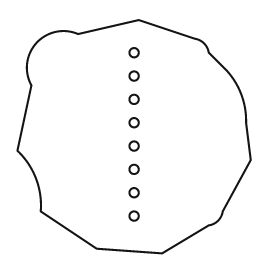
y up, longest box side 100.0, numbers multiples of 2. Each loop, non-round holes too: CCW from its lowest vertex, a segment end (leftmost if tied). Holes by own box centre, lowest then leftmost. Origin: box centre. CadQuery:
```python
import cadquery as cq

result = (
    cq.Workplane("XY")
    .moveTo(12.0, -50.0)
    .lineTo(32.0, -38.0)
    .threePointArc((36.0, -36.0), (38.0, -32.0))
    .lineTo(50.0, -10.0)
    .lineTo(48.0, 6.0)
    .threePointArc((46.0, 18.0), (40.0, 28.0))
    .lineTo(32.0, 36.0)
    .threePointArc((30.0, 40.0), (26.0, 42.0))
    .lineTo(2.0, 50.0)
    .lineTo(-24.0, 44.0)
    .threePointArc((-42.0, 40.0), (-44.0, 22.0))
    .lineTo(-50.0, -6.0)
    .threePointArc((-42.0, -18.0), (-40.0, -32.0))
    .lineTo(-16.0, -48.0)
    .close()
    .moveTo(0.0, -34.0)
    .circle(2.0)
    .moveTo(0.0, -24.0)
    .circle(2.0)
    .moveTo(0.0, -14.0)
    .circle(2.0)
    .moveTo(0.0, -4.0)
    .circle(2.0)
    .moveTo(0.0, 6.0)
    .circle(2.0)
    .moveTo(0.0, 16.0)
    .circle(2.0)
    .moveTo(0.0, 26.0)
    .circle(2.0)
    .moveTo(0.0, 36.0)
    .circle(2.0)
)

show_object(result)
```